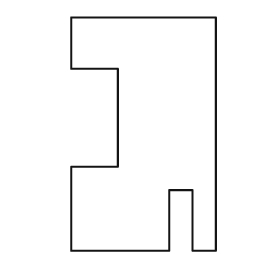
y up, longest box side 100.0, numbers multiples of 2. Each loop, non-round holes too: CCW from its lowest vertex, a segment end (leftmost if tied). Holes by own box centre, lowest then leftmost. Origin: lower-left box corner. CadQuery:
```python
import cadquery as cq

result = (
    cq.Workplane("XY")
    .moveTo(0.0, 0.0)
    .lineTo(42.0, 0.0)
    .lineTo(42.0, 26.0)
    .lineTo(52.0, 26.0)
    .lineTo(52.0, 0.0)
    .lineTo(62.0, 0.0)
    .lineTo(62.0, 100.0)
    .lineTo(0.0, 100.0)
    .lineTo(0.0, 78.0)
    .lineTo(20.0, 78.0)
    .lineTo(20.0, 36.0)
    .lineTo(0.0, 36.0)
    .close()
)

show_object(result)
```